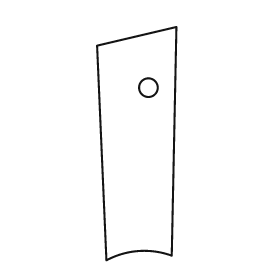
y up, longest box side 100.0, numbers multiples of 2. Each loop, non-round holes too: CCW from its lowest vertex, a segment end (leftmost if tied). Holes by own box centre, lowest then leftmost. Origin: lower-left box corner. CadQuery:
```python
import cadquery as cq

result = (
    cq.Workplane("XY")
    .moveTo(4.0, 0.0)
    .threePointArc((18.0, 4.0), (32.0, 2.0))
    .lineTo(34.0, 100.0)
    .lineTo(0.0, 92.0)
    .close()
    .moveTo(22.0, 74.0)
    .circle(4.0)
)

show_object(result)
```